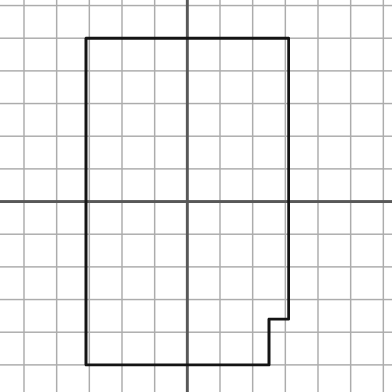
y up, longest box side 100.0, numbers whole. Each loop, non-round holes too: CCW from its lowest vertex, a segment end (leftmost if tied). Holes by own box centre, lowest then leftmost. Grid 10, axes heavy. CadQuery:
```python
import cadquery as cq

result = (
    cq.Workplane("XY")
    .moveTo(-31.0, -50.0)
    .lineTo(25.0, -50.0)
    .lineTo(25.0, -36.0)
    .lineTo(31.0, -36.0)
    .lineTo(31.0, 50.0)
    .lineTo(-31.0, 50.0)
    .close()
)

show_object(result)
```